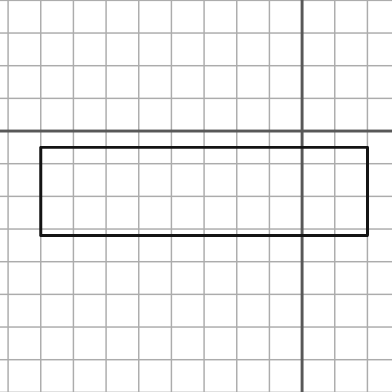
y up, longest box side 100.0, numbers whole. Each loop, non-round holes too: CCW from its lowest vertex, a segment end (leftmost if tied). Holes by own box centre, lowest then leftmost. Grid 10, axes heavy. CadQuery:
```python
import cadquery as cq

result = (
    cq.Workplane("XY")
    .moveTo(-80.0, -32.0)
    .lineTo(20.0, -32.0)
    .lineTo(20.0, -5.0)
    .lineTo(-80.0, -5.0)
    .close()
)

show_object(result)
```